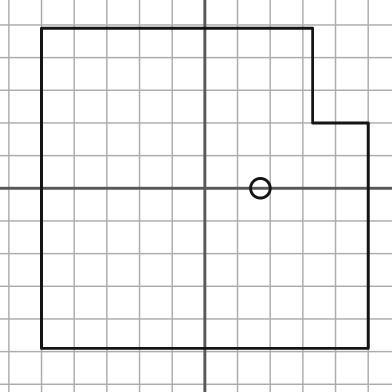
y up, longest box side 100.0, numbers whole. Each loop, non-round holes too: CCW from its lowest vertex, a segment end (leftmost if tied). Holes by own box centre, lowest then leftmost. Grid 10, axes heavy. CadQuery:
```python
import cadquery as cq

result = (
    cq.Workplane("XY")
    .moveTo(-50.0, -49.0)
    .lineTo(50.0, -49.0)
    .lineTo(50.0, 20.0)
    .lineTo(33.0, 20.0)
    .lineTo(33.0, 49.0)
    .lineTo(-50.0, 49.0)
    .close()
    .moveTo(17.0, 0.0)
    .circle(3.0)
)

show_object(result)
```